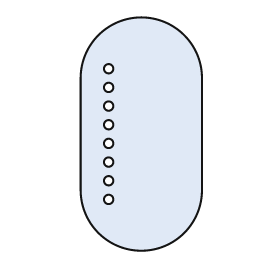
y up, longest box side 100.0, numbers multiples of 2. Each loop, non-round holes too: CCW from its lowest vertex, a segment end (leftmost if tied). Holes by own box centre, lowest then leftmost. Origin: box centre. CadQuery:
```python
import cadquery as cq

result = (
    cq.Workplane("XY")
    .moveTo(-26.0, -24.0)
    .threePointArc((0.0, -50.0), (26.0, -24.0))
    .lineTo(26.0, 24.0)
    .threePointArc((0.0, 50.0), (-26.0, 24.0))
    .close()
    .moveTo(-14.0, -28.0)
    .circle(2.0)
    .moveTo(-14.0, -20.0)
    .circle(2.0)
    .moveTo(-14.0, -12.0)
    .circle(2.0)
    .moveTo(-14.0, -4.0)
    .circle(2.0)
    .moveTo(-14.0, 4.0)
    .circle(2.0)
    .moveTo(-14.0, 12.0)
    .circle(2.0)
    .moveTo(-14.0, 20.0)
    .circle(2.0)
    .moveTo(-14.0, 28.0)
    .circle(2.0)
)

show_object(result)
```